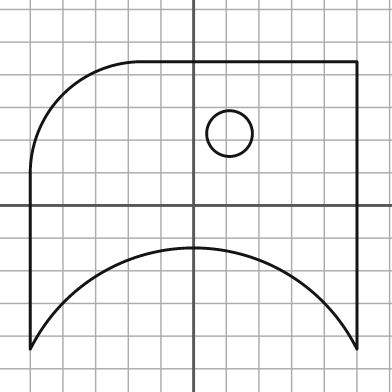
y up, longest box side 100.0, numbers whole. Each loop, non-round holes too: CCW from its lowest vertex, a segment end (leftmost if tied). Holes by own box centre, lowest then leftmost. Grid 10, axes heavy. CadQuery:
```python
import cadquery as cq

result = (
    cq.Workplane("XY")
    .moveTo(-50.0, -44.0)
    .threePointArc((0.0, -13.0), (50.0, -44.0))
    .lineTo(50.0, 44.0)
    .lineTo(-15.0, 44.0)
    .threePointArc((-40.0, 34.0), (-50.0, 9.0))
    .close()
    .moveTo(11.0, 22.0)
    .circle(7.0)
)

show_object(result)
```